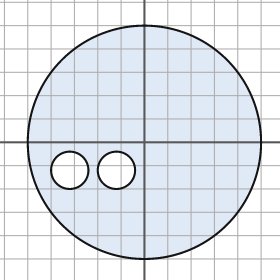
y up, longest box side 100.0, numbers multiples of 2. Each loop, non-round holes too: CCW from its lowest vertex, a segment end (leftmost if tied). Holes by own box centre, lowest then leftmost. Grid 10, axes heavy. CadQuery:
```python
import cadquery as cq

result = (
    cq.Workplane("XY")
    .moveTo(0.0, 0.0)
    .circle(50.0)
    .moveTo(-32.0, -12.0)
    .circle(8.0)
    .moveTo(-12.0, -12.0)
    .circle(8.0)
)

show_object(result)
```